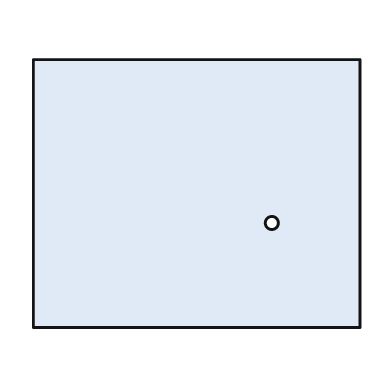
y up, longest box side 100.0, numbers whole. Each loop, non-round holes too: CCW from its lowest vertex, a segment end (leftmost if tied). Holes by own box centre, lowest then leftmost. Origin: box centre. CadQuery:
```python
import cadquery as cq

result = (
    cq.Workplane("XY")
    .moveTo(-50.0, -41.0)
    .lineTo(50.0, -41.0)
    .lineTo(50.0, 41.0)
    .lineTo(-50.0, 41.0)
    .close()
    .moveTo(23.0, -9.0)
    .circle(2.0)
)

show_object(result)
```